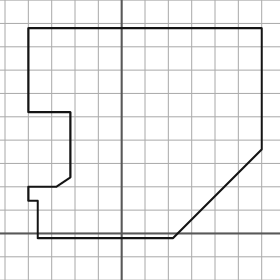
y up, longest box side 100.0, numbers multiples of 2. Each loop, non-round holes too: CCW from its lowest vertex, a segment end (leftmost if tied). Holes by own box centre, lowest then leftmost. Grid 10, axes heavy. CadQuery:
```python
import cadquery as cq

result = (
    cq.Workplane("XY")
    .moveTo(-36.0, -2.0)
    .lineTo(22.0, -2.0)
    .lineTo(60.0, 36.0)
    .lineTo(60.0, 88.0)
    .lineTo(-40.0, 88.0)
    .lineTo(-40.0, 52.0)
    .lineTo(-22.0, 52.0)
    .lineTo(-22.0, 24.0)
    .lineTo(-28.0, 20.0)
    .lineTo(-40.0, 20.0)
    .lineTo(-40.0, 14.0)
    .lineTo(-36.0, 14.0)
    .close()
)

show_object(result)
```